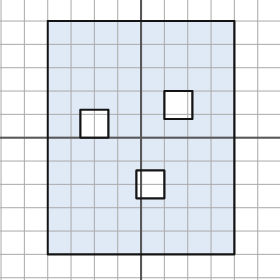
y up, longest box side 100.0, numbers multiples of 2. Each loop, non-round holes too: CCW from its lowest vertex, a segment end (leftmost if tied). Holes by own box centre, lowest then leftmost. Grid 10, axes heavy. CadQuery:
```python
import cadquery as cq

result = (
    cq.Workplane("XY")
    .moveTo(-40.0, -50.0)
    .lineTo(40.0, -50.0)
    .lineTo(40.0, 50.0)
    .lineTo(-40.0, 50.0)
    .close()
    .moveTo(-2.0, -26.0)
    .lineTo(10.0, -26.0)
    .lineTo(10.0, -14.0)
    .lineTo(-2.0, -14.0)
    .close()
    .moveTo(-26.0, 0.0)
    .lineTo(-14.0, 0.0)
    .lineTo(-14.0, 12.0)
    .lineTo(-26.0, 12.0)
    .close()
    .moveTo(10.0, 8.0)
    .lineTo(22.0, 8.0)
    .lineTo(22.0, 20.0)
    .lineTo(10.0, 20.0)
    .close()
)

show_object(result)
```